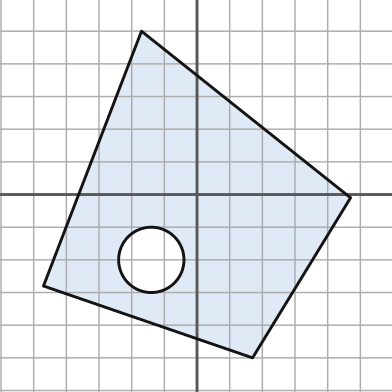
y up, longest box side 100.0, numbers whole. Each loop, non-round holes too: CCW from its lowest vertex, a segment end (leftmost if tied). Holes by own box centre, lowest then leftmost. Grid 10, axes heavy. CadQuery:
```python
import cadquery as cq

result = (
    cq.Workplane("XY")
    .moveTo(17.0, -50.0)
    .lineTo(47.0, -1.0)
    .lineTo(-17.0, 50.0)
    .lineTo(-47.0, -28.0)
    .close()
    .moveTo(-14.0, -20.0)
    .circle(10.0)
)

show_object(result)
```